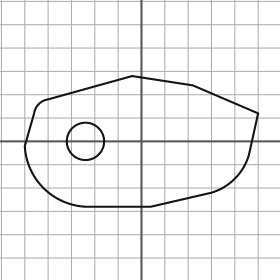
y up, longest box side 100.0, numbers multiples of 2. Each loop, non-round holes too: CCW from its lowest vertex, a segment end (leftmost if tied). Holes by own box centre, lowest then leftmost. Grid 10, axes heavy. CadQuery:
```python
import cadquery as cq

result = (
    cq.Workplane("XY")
    .moveTo(-24.0, -28.0)
    .lineTo(4.0, -28.0)
    .lineTo(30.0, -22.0)
    .threePointArc((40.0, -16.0), (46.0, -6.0))
    .lineTo(50.0, 12.0)
    .lineTo(22.0, 24.0)
    .lineTo(-4.0, 28.0)
    .lineTo(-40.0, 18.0)
    .threePointArc((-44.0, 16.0), (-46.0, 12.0))
    .lineTo(-50.0, -2.0)
    .threePointArc((-42.0, -20.0), (-24.0, -28.0))
    .close()
    .moveTo(-24.0, 0.0)
    .circle(8.0)
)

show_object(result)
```